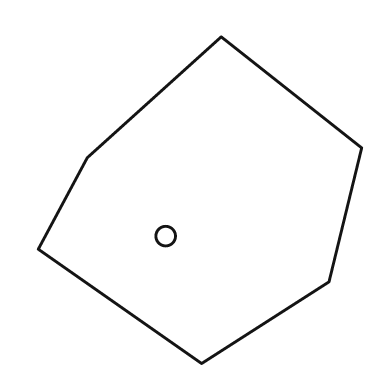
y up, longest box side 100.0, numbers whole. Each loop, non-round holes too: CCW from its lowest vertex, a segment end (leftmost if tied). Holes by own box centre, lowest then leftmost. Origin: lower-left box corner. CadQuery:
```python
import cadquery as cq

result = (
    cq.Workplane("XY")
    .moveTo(50.0, 0.0)
    .lineTo(89.0, 25.0)
    .lineTo(99.0, 66.0)
    .lineTo(56.0, 100.0)
    .lineTo(15.0, 63.0)
    .lineTo(0.0, 35.0)
    .close()
    .moveTo(39.0, 39.0)
    .circle(3.0)
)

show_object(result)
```